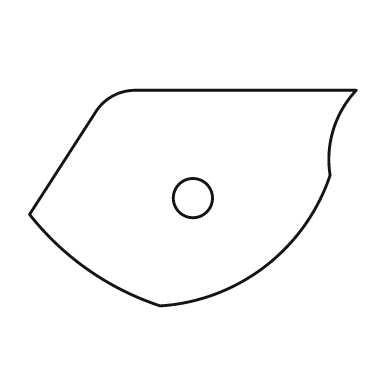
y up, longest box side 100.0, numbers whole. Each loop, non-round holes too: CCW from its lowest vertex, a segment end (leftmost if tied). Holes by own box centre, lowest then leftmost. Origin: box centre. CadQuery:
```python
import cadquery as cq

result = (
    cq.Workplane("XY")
    .moveTo(-10.0, -33.0)
    .threePointArc((22.0, -21.0), (42.0, 7.0))
    .threePointArc((43.0, 21.0), (50.0, 33.0))
    .lineTo(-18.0, 33.0)
    .threePointArc((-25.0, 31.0), (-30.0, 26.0))
    .lineTo(-50.0, -5.0)
    .threePointArc((-32.0, -22.0), (-10.0, -33.0))
    .close()
    .moveTo(0.0, 0.0)
    .circle(6.0)
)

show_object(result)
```